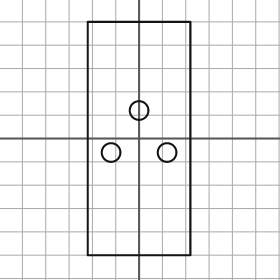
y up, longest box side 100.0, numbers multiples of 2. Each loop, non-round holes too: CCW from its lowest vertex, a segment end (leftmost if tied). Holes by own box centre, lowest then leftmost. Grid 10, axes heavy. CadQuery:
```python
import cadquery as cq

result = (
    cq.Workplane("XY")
    .moveTo(-22.0, -50.0)
    .lineTo(22.0, -50.0)
    .lineTo(22.0, 50.0)
    .lineTo(-22.0, 50.0)
    .close()
    .moveTo(-12.0, -6.0)
    .circle(4.0)
    .moveTo(12.0, -6.0)
    .circle(4.0)
    .moveTo(0.0, 12.0)
    .circle(4.0)
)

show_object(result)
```